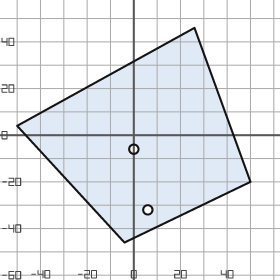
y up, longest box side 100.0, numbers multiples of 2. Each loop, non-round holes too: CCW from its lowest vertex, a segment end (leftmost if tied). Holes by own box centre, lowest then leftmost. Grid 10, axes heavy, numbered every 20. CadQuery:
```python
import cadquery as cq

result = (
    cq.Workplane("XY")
    .moveTo(-4.0, -46.0)
    .lineTo(50.0, -20.0)
    .lineTo(26.0, 46.0)
    .lineTo(-50.0, 4.0)
    .close()
    .moveTo(6.0, -32.0)
    .circle(2.0)
    .moveTo(0.0, -6.0)
    .circle(2.0)
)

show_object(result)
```